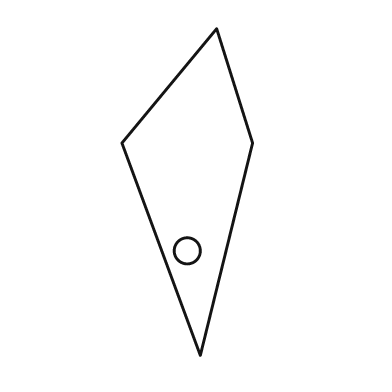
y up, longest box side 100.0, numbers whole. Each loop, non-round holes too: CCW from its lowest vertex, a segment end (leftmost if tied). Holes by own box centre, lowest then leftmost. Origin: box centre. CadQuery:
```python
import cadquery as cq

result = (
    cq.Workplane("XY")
    .moveTo(4.0, -50.0)
    .lineTo(20.0, 15.0)
    .lineTo(9.0, 50.0)
    .lineTo(-20.0, 15.0)
    .close()
    .moveTo(0.0, -18.0)
    .circle(4.0)
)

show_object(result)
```